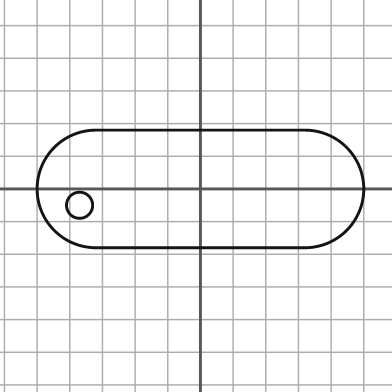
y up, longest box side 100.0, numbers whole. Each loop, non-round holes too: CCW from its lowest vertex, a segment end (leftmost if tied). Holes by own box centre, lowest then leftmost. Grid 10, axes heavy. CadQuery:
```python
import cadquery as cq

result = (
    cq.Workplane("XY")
    .moveTo(-32.0, -18.0)
    .lineTo(32.0, -18.0)
    .threePointArc((50.0, 0.0), (32.0, 18.0))
    .lineTo(-32.0, 18.0)
    .threePointArc((-50.0, 0.0), (-32.0, -18.0))
    .close()
    .moveTo(-37.0, -5.0)
    .circle(4.0)
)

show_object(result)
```